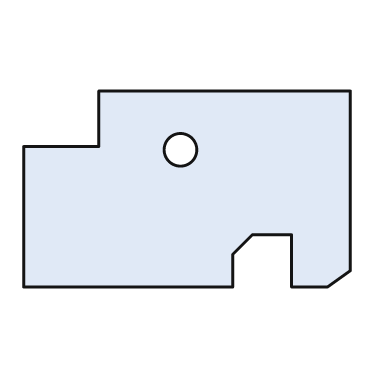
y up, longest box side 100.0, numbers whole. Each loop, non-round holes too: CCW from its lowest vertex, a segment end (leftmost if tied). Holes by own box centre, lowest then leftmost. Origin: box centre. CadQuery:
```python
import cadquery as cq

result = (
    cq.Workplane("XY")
    .moveTo(-50.0, -30.0)
    .lineTo(14.0, -30.0)
    .lineTo(14.0, -20.0)
    .lineTo(20.0, -14.0)
    .lineTo(32.0, -14.0)
    .lineTo(32.0, -30.0)
    .lineTo(43.0, -30.0)
    .lineTo(50.0, -25.0)
    .lineTo(50.0, 30.0)
    .lineTo(-27.0, 30.0)
    .lineTo(-27.0, 13.0)
    .lineTo(-50.0, 13.0)
    .close()
    .moveTo(-2.0, 12.0)
    .circle(5.0)
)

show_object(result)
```